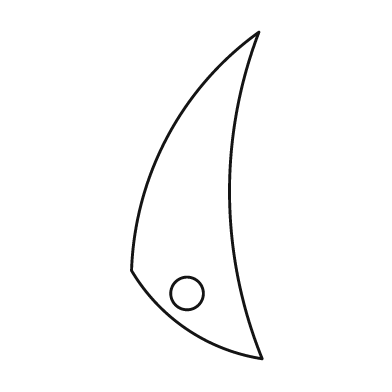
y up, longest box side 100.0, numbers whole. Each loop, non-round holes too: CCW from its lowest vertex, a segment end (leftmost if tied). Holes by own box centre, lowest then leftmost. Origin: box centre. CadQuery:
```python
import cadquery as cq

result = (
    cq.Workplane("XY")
    .moveTo(20.0, -50.0)
    .threePointArc((10.0, 0.0), (19.0, 50.0))
    .threePointArc((-9.0, 18.0), (-20.0, -23.0))
    .threePointArc((-3.0, -41.0), (20.0, -50.0))
    .close()
    .moveTo(-3.0, -30.0)
    .circle(5.0)
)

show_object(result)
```